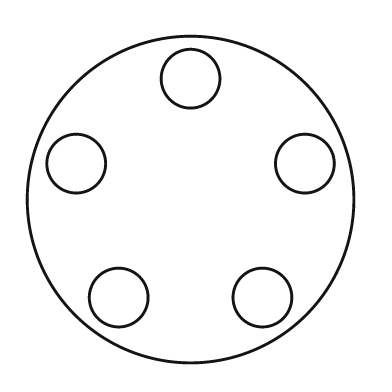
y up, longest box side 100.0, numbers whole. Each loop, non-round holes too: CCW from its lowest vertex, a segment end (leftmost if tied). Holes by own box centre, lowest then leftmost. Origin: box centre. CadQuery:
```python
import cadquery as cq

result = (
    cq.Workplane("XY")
    .moveTo(0.0, 0.0)
    .circle(50.0)
    .moveTo(-22.0, -30.0)
    .circle(9.0)
    .moveTo(22.0, -30.0)
    .circle(9.0)
    .moveTo(-35.0, 11.0)
    .circle(9.0)
    .moveTo(35.0, 11.0)
    .circle(9.0)
    .moveTo(0.0, 37.0)
    .circle(9.0)
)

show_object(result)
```